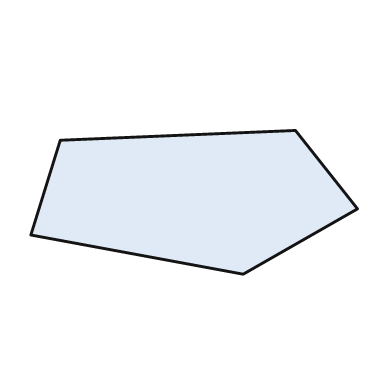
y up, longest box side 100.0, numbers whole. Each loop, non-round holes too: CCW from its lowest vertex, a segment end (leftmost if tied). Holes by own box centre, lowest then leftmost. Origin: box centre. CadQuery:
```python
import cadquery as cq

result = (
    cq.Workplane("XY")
    .moveTo(15.0, -22.0)
    .lineTo(50.0, -2.0)
    .lineTo(31.0, 22.0)
    .lineTo(-41.0, 19.0)
    .lineTo(-50.0, -10.0)
    .close()
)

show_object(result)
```